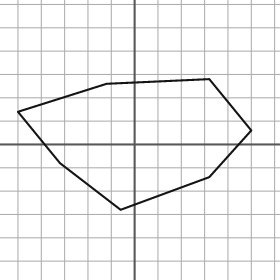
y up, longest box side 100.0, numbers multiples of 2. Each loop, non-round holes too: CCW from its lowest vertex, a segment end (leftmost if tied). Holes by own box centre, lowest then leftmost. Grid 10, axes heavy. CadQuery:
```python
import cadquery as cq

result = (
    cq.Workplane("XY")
    .moveTo(-6.0, -28.0)
    .lineTo(32.0, -14.0)
    .lineTo(50.0, 6.0)
    .lineTo(32.0, 28.0)
    .lineTo(-12.0, 26.0)
    .lineTo(-50.0, 14.0)
    .lineTo(-32.0, -8.0)
    .close()
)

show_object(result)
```